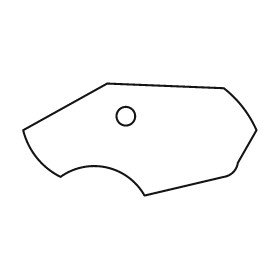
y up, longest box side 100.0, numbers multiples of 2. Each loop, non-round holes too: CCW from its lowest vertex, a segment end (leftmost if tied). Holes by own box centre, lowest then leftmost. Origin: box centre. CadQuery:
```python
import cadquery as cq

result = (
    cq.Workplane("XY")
    .moveTo(2.0, -24.0)
    .lineTo(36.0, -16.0)
    .threePointArc((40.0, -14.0), (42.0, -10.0))
    .lineTo(50.0, 4.0)
    .threePointArc((44.0, 14.0), (36.0, 22.0))
    .lineTo(-14.0, 24.0)
    .lineTo(-50.0, 4.0)
    .threePointArc((-44.0, -8.0), (-34.0, -16.0))
    .threePointArc((-14.0, -12.0), (2.0, -24.0))
    .close()
    .moveTo(-6.0, 10.0)
    .circle(4.0)
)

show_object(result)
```